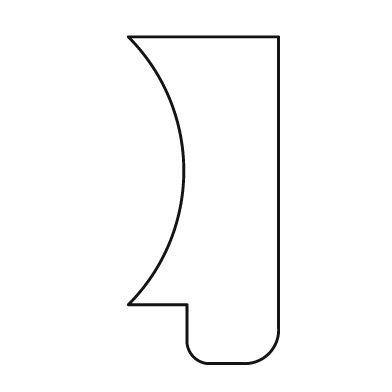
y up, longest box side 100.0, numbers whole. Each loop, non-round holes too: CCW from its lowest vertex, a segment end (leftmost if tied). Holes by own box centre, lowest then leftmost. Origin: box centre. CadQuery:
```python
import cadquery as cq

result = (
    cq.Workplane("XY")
    .moveTo(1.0, -50.0)
    .lineTo(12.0, -50.0)
    .threePointArc((20.0, -47.0), (23.0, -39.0))
    .lineTo(23.0, 50.0)
    .lineTo(-23.0, 50.0)
    .threePointArc((-6.0, 9.0), (-23.0, -32.0))
    .lineTo(-5.0, -32.0)
    .lineTo(-5.0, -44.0)
    .threePointArc((-3.0, -48.0), (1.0, -50.0))
    .close()
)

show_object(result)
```